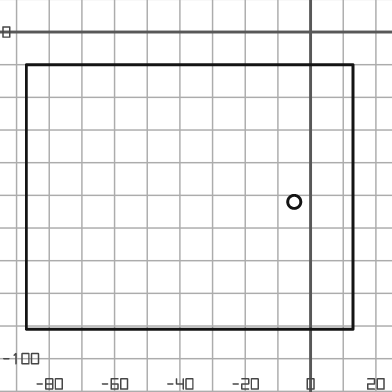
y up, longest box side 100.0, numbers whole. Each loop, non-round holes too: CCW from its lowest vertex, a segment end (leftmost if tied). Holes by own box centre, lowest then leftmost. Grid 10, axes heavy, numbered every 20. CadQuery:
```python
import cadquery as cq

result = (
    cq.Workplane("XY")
    .moveTo(-87.0, -91.0)
    .lineTo(13.0, -91.0)
    .lineTo(13.0, -10.0)
    .lineTo(-87.0, -10.0)
    .close()
    .moveTo(-5.0, -52.0)
    .circle(2.0)
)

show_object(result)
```